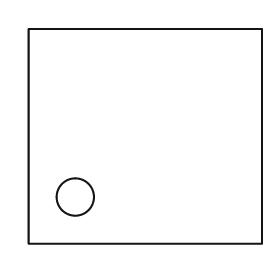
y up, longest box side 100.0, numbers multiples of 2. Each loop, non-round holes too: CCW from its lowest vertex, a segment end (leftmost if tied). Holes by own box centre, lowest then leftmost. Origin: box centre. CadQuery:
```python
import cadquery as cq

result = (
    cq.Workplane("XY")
    .moveTo(-50.0, -46.0)
    .lineTo(50.0, -46.0)
    .lineTo(50.0, 46.0)
    .lineTo(-50.0, 46.0)
    .close()
    .moveTo(-30.0, -26.0)
    .circle(8.0)
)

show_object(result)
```